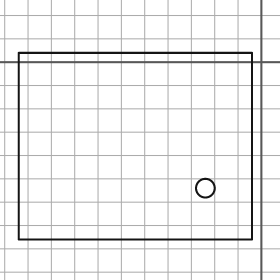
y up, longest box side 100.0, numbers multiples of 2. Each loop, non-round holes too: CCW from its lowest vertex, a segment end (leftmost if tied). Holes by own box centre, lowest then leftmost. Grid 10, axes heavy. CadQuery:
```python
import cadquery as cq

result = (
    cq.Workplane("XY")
    .moveTo(-104.0, -76.0)
    .lineTo(-4.0, -76.0)
    .lineTo(-4.0, 4.0)
    .lineTo(-104.0, 4.0)
    .close()
    .moveTo(-24.0, -54.0)
    .circle(4.0)
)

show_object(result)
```